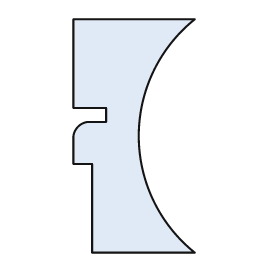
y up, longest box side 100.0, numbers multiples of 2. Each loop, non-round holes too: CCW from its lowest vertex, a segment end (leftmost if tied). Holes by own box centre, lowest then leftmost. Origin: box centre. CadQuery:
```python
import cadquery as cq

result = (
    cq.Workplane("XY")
    .moveTo(-18.0, -50.0)
    .lineTo(26.0, -50.0)
    .threePointArc((2.0, 0.0), (26.0, 50.0))
    .lineTo(-26.0, 50.0)
    .lineTo(-26.0, 12.0)
    .lineTo(-12.0, 12.0)
    .lineTo(-12.0, 6.0)
    .lineTo(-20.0, 6.0)
    .threePointArc((-24.0, 4.0), (-26.0, 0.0))
    .lineTo(-26.0, -12.0)
    .lineTo(-18.0, -12.0)
    .close()
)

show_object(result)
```